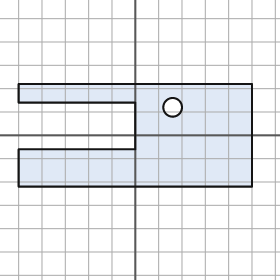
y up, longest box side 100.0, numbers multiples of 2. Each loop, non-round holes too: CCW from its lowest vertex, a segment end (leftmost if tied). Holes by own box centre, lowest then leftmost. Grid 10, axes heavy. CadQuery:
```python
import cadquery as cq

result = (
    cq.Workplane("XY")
    .moveTo(-50.0, -22.0)
    .lineTo(50.0, -22.0)
    .lineTo(50.0, 22.0)
    .lineTo(-50.0, 22.0)
    .lineTo(-50.0, 14.0)
    .lineTo(0.0, 14.0)
    .lineTo(0.0, -6.0)
    .lineTo(-50.0, -6.0)
    .close()
    .moveTo(16.0, 12.0)
    .circle(4.0)
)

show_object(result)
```